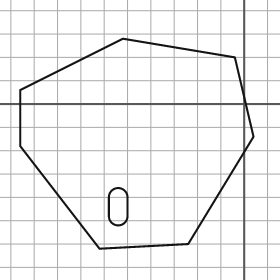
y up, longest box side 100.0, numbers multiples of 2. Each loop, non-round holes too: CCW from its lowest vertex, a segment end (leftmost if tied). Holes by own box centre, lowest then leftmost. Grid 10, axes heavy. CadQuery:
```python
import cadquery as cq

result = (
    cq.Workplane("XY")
    .moveTo(-62.0, -62.0)
    .lineTo(-24.0, -60.0)
    .lineTo(4.0, -14.0)
    .lineTo(-4.0, 20.0)
    .lineTo(-52.0, 28.0)
    .lineTo(-96.0, 6.0)
    .lineTo(-96.0, -18.0)
    .close()
    .moveTo(-58.0, -48.0)
    .threePointArc((-54.0, -52.0), (-50.0, -48.0))
    .lineTo(-50.0, -40.0)
    .threePointArc((-54.0, -36.0), (-58.0, -40.0))
    .close()
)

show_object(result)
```